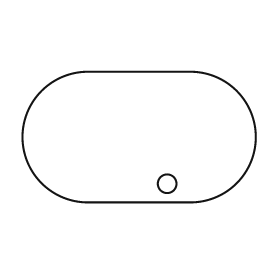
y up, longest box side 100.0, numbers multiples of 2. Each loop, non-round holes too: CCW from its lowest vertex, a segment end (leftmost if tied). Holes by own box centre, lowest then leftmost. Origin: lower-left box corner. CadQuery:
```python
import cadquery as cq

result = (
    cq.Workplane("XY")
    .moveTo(28.0, 0.0)
    .lineTo(72.0, 0.0)
    .threePointArc((100.0, 28.0), (72.0, 56.0))
    .lineTo(28.0, 56.0)
    .threePointArc((0.0, 28.0), (28.0, 0.0))
    .close()
    .moveTo(62.0, 8.0)
    .circle(4.0)
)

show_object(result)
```